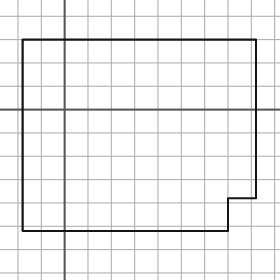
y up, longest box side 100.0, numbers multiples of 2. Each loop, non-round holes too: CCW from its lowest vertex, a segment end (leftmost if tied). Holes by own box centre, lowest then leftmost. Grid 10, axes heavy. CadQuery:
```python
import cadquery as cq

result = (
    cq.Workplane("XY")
    .moveTo(-18.0, -52.0)
    .lineTo(70.0, -52.0)
    .lineTo(70.0, -38.0)
    .lineTo(82.0, -38.0)
    .lineTo(82.0, 30.0)
    .lineTo(-18.0, 30.0)
    .close()
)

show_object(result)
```